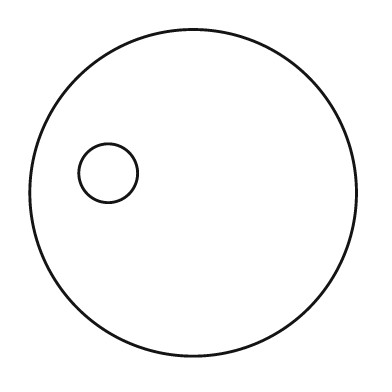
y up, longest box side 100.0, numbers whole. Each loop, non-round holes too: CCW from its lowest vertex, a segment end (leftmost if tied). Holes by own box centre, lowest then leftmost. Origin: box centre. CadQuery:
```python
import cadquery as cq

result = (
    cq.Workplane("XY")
    .moveTo(0.0, 0.0)
    .circle(50.0)
    .moveTo(-26.0, 6.0)
    .circle(9.0)
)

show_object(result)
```